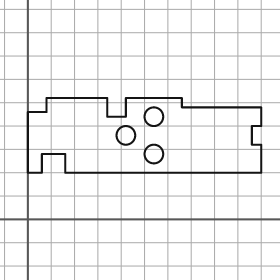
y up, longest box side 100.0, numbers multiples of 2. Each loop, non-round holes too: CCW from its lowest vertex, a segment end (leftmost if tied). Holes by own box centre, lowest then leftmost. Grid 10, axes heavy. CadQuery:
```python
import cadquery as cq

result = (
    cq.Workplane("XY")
    .moveTo(0.0, 20.0)
    .lineTo(6.0, 20.0)
    .lineTo(6.0, 28.0)
    .lineTo(16.0, 28.0)
    .lineTo(16.0, 20.0)
    .lineTo(100.0, 20.0)
    .lineTo(100.0, 32.0)
    .lineTo(96.0, 32.0)
    .lineTo(96.0, 40.0)
    .lineTo(100.0, 40.0)
    .lineTo(100.0, 48.0)
    .lineTo(66.0, 48.0)
    .lineTo(66.0, 52.0)
    .lineTo(42.0, 52.0)
    .lineTo(42.0, 44.0)
    .lineTo(34.0, 44.0)
    .lineTo(34.0, 52.0)
    .lineTo(8.0, 52.0)
    .lineTo(8.0, 46.0)
    .lineTo(0.0, 46.0)
    .close()
    .moveTo(54.0, 28.0)
    .circle(4.0)
    .moveTo(42.0, 36.0)
    .circle(4.0)
    .moveTo(54.0, 44.0)
    .circle(4.0)
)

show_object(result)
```